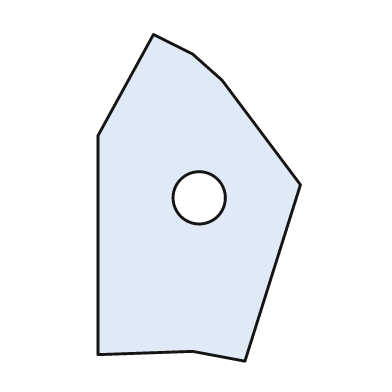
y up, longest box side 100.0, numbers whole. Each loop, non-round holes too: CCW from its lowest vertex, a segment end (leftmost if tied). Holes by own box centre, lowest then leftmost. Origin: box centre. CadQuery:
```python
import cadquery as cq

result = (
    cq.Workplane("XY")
    .moveTo(14.0, -50.0)
    .lineTo(31.0, 4.0)
    .lineTo(7.0, 36.0)
    .lineTo(-2.0, 44.0)
    .lineTo(-14.0, 50.0)
    .lineTo(-31.0, 19.0)
    .lineTo(-31.0, -48.0)
    .lineTo(-2.0, -47.0)
    .close()
    .moveTo(0.0, 0.0)
    .circle(8.0)
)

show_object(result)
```